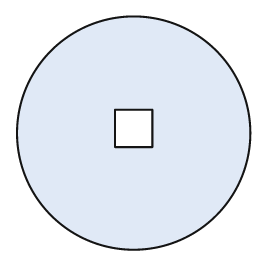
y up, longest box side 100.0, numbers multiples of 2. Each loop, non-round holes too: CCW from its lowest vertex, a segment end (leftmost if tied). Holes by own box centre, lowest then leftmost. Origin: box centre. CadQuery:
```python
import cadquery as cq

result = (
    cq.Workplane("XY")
    .moveTo(0.0, 0.0)
    .circle(50.0)
    .moveTo(-8.0, -6.0)
    .lineTo(8.0, -6.0)
    .lineTo(8.0, 10.0)
    .lineTo(-8.0, 10.0)
    .close()
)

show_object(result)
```